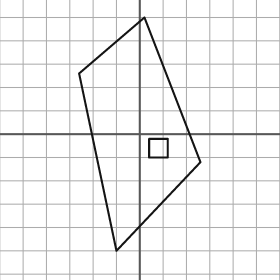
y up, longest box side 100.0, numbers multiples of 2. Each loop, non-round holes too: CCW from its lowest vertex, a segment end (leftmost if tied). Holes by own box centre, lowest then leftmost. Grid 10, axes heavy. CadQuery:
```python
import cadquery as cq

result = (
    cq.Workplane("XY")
    .moveTo(-10.0, -50.0)
    .lineTo(26.0, -12.0)
    .lineTo(2.0, 50.0)
    .lineTo(-26.0, 26.0)
    .close()
    .moveTo(4.0, -10.0)
    .lineTo(12.0, -10.0)
    .lineTo(12.0, -2.0)
    .lineTo(4.0, -2.0)
    .close()
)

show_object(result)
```